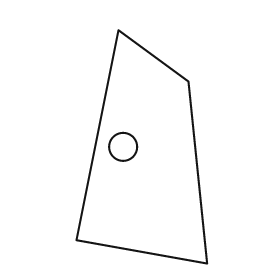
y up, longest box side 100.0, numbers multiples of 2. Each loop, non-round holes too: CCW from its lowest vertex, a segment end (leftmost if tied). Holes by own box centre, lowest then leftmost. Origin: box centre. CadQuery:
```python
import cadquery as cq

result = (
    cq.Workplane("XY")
    .moveTo(28.0, -50.0)
    .lineTo(20.0, 28.0)
    .lineTo(-10.0, 50.0)
    .lineTo(-28.0, -40.0)
    .close()
    .moveTo(-8.0, 0.0)
    .circle(6.0)
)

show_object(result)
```